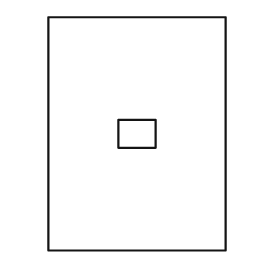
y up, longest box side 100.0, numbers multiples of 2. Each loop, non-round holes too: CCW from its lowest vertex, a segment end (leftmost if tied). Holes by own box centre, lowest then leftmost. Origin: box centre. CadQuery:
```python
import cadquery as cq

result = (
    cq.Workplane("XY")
    .moveTo(-38.0, -50.0)
    .lineTo(38.0, -50.0)
    .lineTo(38.0, 50.0)
    .lineTo(-38.0, 50.0)
    .close()
    .moveTo(-8.0, -6.0)
    .lineTo(8.0, -6.0)
    .lineTo(8.0, 6.0)
    .lineTo(-8.0, 6.0)
    .close()
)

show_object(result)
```